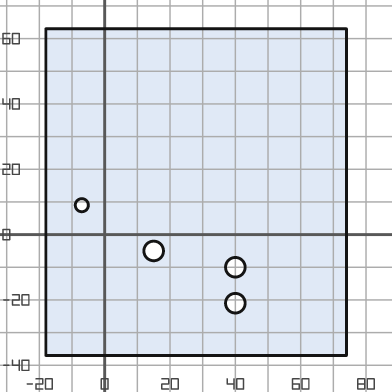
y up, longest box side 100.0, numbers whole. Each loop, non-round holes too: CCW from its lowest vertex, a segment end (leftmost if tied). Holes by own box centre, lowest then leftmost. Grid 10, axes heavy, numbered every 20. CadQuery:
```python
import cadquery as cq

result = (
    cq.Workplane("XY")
    .moveTo(-18.0, -37.0)
    .lineTo(74.0, -37.0)
    .lineTo(74.0, 63.0)
    .lineTo(-18.0, 63.0)
    .close()
    .moveTo(40.0, -21.0)
    .circle(3.0)
    .moveTo(40.0, -10.0)
    .circle(3.0)
    .moveTo(15.0, -5.0)
    .circle(3.0)
    .moveTo(-7.0, 9.0)
    .circle(2.0)
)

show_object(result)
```